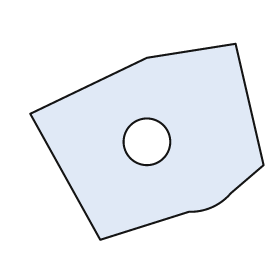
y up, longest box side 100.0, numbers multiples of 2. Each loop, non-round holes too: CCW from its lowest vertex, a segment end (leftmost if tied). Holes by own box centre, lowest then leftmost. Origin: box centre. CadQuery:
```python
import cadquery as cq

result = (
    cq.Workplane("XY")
    .moveTo(-20.0, -42.0)
    .lineTo(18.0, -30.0)
    .threePointArc((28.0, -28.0), (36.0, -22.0))
    .lineTo(50.0, -10.0)
    .lineTo(38.0, 42.0)
    .lineTo(0.0, 36.0)
    .lineTo(-50.0, 12.0)
    .close()
    .moveTo(0.0, 0.0)
    .circle(10.0)
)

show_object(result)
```